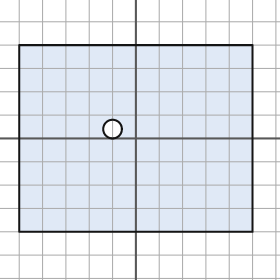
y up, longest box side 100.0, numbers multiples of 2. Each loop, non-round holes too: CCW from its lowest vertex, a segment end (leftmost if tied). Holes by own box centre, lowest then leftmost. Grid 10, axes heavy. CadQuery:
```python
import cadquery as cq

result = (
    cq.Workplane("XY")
    .moveTo(-50.0, -40.0)
    .lineTo(50.0, -40.0)
    .lineTo(50.0, 40.0)
    .lineTo(-50.0, 40.0)
    .close()
    .moveTo(-10.0, 4.0)
    .circle(4.0)
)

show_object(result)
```